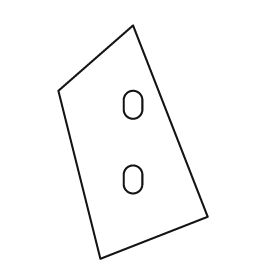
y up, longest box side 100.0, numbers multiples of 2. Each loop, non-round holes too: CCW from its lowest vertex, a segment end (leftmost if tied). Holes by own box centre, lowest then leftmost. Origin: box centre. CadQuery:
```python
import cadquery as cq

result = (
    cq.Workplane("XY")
    .moveTo(-14.0, -50.0)
    .lineTo(32.0, -32.0)
    .lineTo(0.0, 50.0)
    .lineTo(-32.0, 22.0)
    .close()
    .moveTo(-4.0, -18.0)
    .threePointArc((0.0, -22.0), (4.0, -18.0))
    .lineTo(4.0, -14.0)
    .threePointArc((0.0, -10.0), (-4.0, -14.0))
    .close()
    .moveTo(-4.0, 14.0)
    .threePointArc((0.0, 10.0), (4.0, 14.0))
    .lineTo(4.0, 18.0)
    .threePointArc((0.0, 22.0), (-4.0, 18.0))
    .close()
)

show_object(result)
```